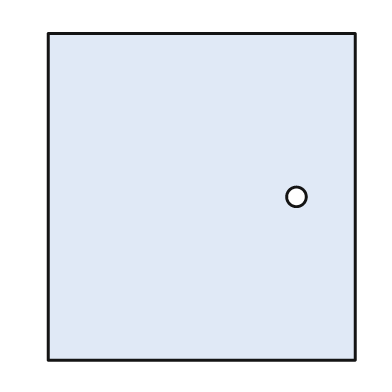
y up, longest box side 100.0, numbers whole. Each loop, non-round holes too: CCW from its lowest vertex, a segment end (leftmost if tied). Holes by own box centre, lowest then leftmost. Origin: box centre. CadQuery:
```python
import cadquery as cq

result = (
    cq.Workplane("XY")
    .moveTo(-47.0, -50.0)
    .lineTo(47.0, -50.0)
    .lineTo(47.0, 50.0)
    .lineTo(-47.0, 50.0)
    .close()
    .moveTo(29.0, 0.0)
    .circle(3.0)
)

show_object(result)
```